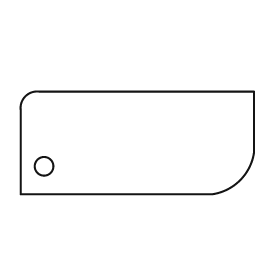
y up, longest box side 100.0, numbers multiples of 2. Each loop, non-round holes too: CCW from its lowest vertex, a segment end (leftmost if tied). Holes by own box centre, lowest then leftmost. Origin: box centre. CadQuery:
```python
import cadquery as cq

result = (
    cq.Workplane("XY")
    .moveTo(-50.0, -22.0)
    .lineTo(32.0, -22.0)
    .threePointArc((44.0, -16.0), (50.0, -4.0))
    .lineTo(50.0, 22.0)
    .lineTo(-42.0, 22.0)
    .threePointArc((-48.0, 20.0), (-50.0, 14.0))
    .close()
    .moveTo(-40.0, -10.0)
    .circle(4.0)
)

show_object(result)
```